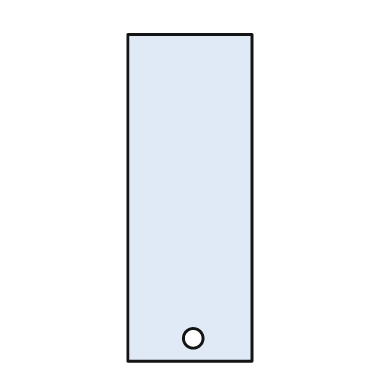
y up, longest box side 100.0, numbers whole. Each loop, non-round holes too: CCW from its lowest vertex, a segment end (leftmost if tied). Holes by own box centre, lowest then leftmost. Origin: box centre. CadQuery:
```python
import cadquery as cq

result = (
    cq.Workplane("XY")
    .moveTo(-19.0, -50.0)
    .lineTo(19.0, -50.0)
    .lineTo(19.0, 50.0)
    .lineTo(-19.0, 50.0)
    .close()
    .moveTo(1.0, -43.0)
    .circle(3.0)
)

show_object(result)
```